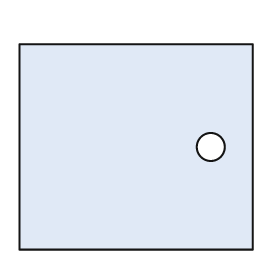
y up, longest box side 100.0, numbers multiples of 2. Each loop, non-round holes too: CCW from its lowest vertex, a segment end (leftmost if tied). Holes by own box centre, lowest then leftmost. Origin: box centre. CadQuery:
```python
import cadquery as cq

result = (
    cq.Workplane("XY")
    .moveTo(-50.0, -44.0)
    .lineTo(50.0, -44.0)
    .lineTo(50.0, 44.0)
    .lineTo(-50.0, 44.0)
    .close()
    .moveTo(32.0, 0.0)
    .circle(6.0)
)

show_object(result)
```